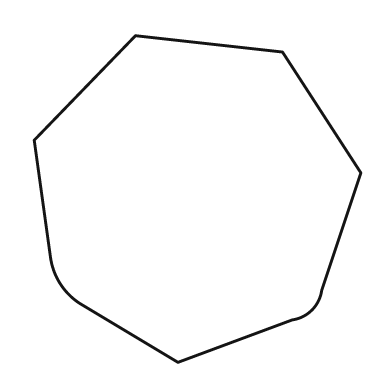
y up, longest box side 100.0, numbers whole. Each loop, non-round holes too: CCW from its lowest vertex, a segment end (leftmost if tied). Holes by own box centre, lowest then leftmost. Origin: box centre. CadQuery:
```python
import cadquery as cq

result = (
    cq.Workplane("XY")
    .moveTo(-6.0, -50.0)
    .lineTo(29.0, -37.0)
    .threePointArc((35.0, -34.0), (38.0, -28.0))
    .lineTo(50.0, 8.0)
    .lineTo(26.0, 45.0)
    .lineTo(-19.0, 50.0)
    .lineTo(-50.0, 18.0)
    .lineTo(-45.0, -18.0)
    .threePointArc((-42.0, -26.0), (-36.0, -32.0))
    .close()
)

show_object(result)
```